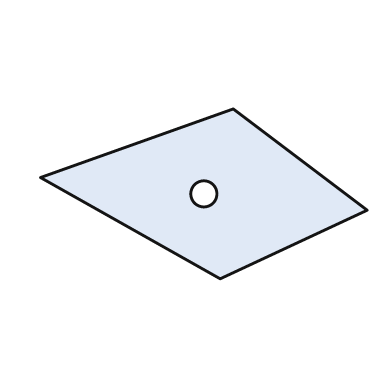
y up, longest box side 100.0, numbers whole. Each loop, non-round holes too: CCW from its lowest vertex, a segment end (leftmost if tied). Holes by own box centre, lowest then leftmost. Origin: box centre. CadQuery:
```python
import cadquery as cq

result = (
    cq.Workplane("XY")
    .moveTo(5.0, -26.0)
    .lineTo(50.0, -5.0)
    .lineTo(9.0, 26.0)
    .lineTo(-50.0, 5.0)
    .close()
    .moveTo(0.0, 0.0)
    .circle(4.0)
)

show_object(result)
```